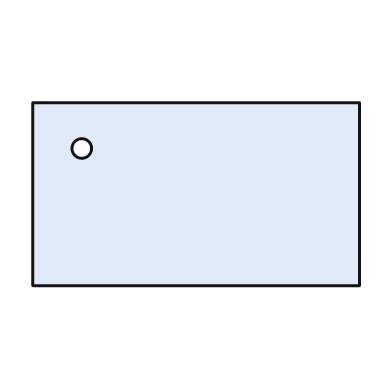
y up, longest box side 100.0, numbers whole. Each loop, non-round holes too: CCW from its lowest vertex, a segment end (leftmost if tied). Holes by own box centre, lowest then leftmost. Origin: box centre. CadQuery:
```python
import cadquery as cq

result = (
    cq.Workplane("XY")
    .moveTo(-50.0, -28.0)
    .lineTo(50.0, -28.0)
    .lineTo(50.0, 28.0)
    .lineTo(-50.0, 28.0)
    .close()
    .moveTo(-35.0, 14.0)
    .circle(3.0)
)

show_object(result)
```